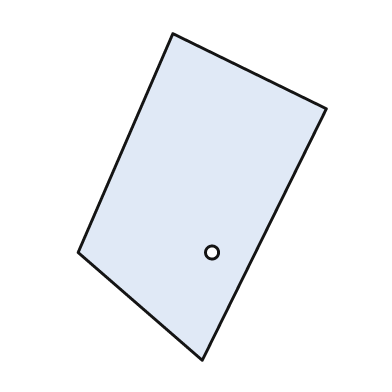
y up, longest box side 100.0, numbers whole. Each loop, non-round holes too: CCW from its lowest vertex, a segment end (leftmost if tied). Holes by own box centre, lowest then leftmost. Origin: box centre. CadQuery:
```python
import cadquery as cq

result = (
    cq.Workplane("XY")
    .moveTo(0.0, -50.0)
    .lineTo(38.0, 27.0)
    .lineTo(-9.0, 50.0)
    .lineTo(-38.0, -17.0)
    .close()
    .moveTo(3.0, -17.0)
    .circle(2.0)
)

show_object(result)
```